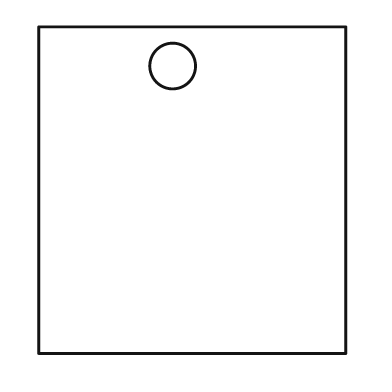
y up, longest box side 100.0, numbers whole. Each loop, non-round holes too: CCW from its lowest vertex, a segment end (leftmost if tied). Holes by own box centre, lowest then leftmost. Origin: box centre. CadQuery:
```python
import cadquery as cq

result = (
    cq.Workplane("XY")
    .moveTo(-47.0, -50.0)
    .lineTo(47.0, -50.0)
    .lineTo(47.0, 50.0)
    .lineTo(-47.0, 50.0)
    .close()
    .moveTo(-6.0, 38.0)
    .circle(7.0)
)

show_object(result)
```